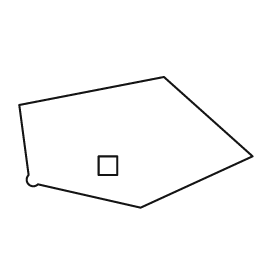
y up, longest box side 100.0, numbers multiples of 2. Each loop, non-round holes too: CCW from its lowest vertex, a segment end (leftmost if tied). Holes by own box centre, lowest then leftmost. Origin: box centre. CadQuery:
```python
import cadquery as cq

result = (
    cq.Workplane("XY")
    .moveTo(2.0, -28.0)
    .lineTo(50.0, -6.0)
    .lineTo(12.0, 28.0)
    .lineTo(-50.0, 16.0)
    .lineTo(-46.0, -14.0)
    .threePointArc((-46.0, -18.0), (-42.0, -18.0))
    .close()
    .moveTo(-16.0, -14.0)
    .lineTo(-8.0, -14.0)
    .lineTo(-8.0, -6.0)
    .lineTo(-16.0, -6.0)
    .close()
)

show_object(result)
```